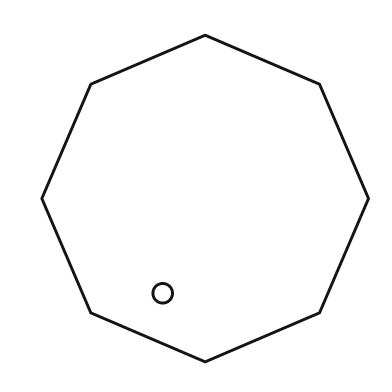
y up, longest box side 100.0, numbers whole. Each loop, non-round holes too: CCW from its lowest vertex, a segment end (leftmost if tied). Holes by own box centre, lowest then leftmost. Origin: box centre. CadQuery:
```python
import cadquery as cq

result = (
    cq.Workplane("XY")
    .moveTo(0.0, -50.0)
    .lineTo(35.0, -35.0)
    .lineTo(50.0, 0.0)
    .lineTo(35.0, 35.0)
    .lineTo(0.0, 50.0)
    .lineTo(-35.0, 35.0)
    .lineTo(-50.0, 0.0)
    .lineTo(-35.0, -35.0)
    .close()
    .moveTo(-13.0, -29.0)
    .circle(3.0)
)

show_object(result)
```